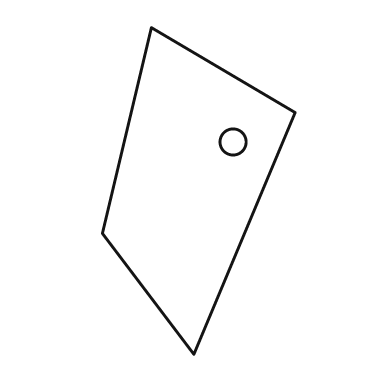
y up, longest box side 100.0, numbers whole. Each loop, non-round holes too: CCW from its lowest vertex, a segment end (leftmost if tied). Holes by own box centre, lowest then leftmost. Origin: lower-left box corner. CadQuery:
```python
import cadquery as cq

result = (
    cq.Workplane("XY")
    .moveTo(28.0, 0.0)
    .lineTo(59.0, 74.0)
    .lineTo(15.0, 100.0)
    .lineTo(0.0, 37.0)
    .close()
    .moveTo(40.0, 65.0)
    .circle(4.0)
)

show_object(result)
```